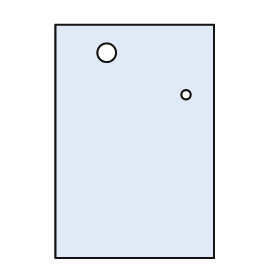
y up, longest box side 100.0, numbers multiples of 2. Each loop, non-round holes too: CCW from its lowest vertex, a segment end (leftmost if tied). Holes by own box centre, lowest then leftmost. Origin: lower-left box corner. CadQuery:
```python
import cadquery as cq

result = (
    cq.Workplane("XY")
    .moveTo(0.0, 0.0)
    .lineTo(68.0, 0.0)
    .lineTo(68.0, 100.0)
    .lineTo(0.0, 100.0)
    .close()
    .moveTo(56.0, 70.0)
    .circle(2.0)
    .moveTo(22.0, 88.0)
    .circle(4.0)
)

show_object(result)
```